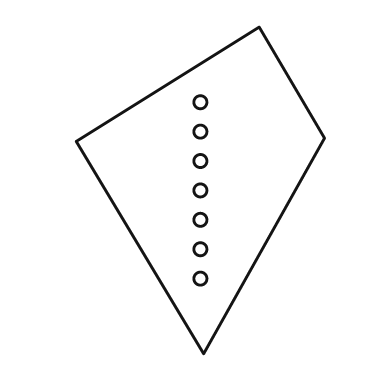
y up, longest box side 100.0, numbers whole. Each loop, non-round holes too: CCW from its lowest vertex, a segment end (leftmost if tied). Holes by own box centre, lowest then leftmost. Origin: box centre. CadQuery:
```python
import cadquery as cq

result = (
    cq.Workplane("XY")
    .moveTo(1.0, -50.0)
    .lineTo(38.0, 16.0)
    .lineTo(18.0, 50.0)
    .lineTo(-38.0, 15.0)
    .close()
    .moveTo(0.0, -27.0)
    .circle(2.0)
    .moveTo(0.0, -18.0)
    .circle(2.0)
    .moveTo(0.0, -9.0)
    .circle(2.0)
    .moveTo(0.0, 0.0)
    .circle(2.0)
    .moveTo(0.0, 9.0)
    .circle(2.0)
    .moveTo(0.0, 18.0)
    .circle(2.0)
    .moveTo(0.0, 27.0)
    .circle(2.0)
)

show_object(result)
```